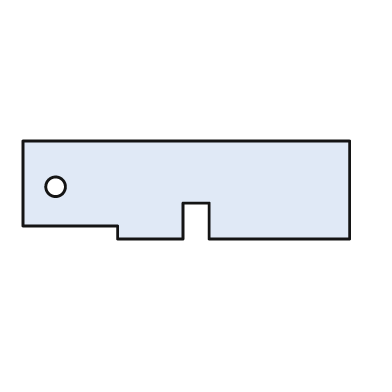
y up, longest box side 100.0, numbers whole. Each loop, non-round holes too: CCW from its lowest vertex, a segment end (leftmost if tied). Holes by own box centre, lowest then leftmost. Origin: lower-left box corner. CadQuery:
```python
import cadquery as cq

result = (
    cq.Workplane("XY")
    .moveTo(29.0, 0.0)
    .lineTo(49.0, 0.0)
    .lineTo(49.0, 11.0)
    .lineTo(57.0, 11.0)
    .lineTo(57.0, 0.0)
    .lineTo(100.0, 0.0)
    .lineTo(100.0, 30.0)
    .lineTo(0.0, 30.0)
    .lineTo(0.0, 4.0)
    .lineTo(29.0, 4.0)
    .close()
    .moveTo(10.0, 16.0)
    .circle(3.0)
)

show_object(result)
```